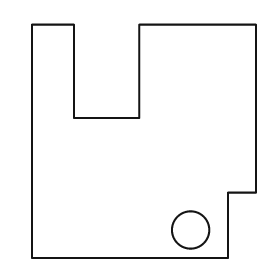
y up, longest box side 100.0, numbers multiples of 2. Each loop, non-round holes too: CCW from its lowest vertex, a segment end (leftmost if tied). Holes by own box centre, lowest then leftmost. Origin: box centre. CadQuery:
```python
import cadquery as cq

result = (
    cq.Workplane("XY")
    .moveTo(-48.0, -50.0)
    .lineTo(36.0, -50.0)
    .lineTo(36.0, -22.0)
    .lineTo(48.0, -22.0)
    .lineTo(48.0, 50.0)
    .lineTo(-2.0, 50.0)
    .lineTo(-2.0, 10.0)
    .lineTo(-30.0, 10.0)
    .lineTo(-30.0, 50.0)
    .lineTo(-48.0, 50.0)
    .close()
    .moveTo(20.0, -38.0)
    .circle(8.0)
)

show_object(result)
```